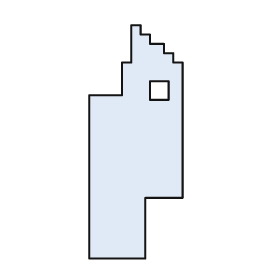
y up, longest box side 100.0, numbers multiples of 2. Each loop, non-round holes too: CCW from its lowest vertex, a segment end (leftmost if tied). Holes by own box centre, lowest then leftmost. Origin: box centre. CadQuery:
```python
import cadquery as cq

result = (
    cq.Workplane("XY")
    .moveTo(-20.0, -50.0)
    .lineTo(4.0, -50.0)
    .lineTo(4.0, -24.0)
    .lineTo(20.0, -24.0)
    .lineTo(20.0, 34.0)
    .lineTo(16.0, 34.0)
    .lineTo(16.0, 38.0)
    .lineTo(12.0, 38.0)
    .lineTo(12.0, 42.0)
    .lineTo(6.0, 42.0)
    .lineTo(6.0, 46.0)
    .lineTo(2.0, 46.0)
    .lineTo(2.0, 50.0)
    .lineTo(-2.0, 50.0)
    .lineTo(-2.0, 34.0)
    .lineTo(-6.0, 34.0)
    .lineTo(-6.0, 20.0)
    .lineTo(-20.0, 20.0)
    .close()
    .moveTo(6.0, 18.0)
    .lineTo(14.0, 18.0)
    .lineTo(14.0, 26.0)
    .lineTo(6.0, 26.0)
    .close()
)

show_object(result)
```